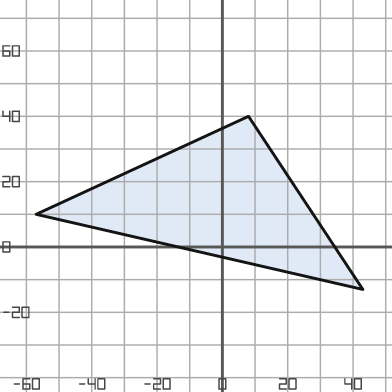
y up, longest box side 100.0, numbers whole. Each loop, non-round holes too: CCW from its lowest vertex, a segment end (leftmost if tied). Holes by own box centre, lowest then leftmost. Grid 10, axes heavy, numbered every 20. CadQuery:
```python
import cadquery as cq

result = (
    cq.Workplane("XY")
    .moveTo(43.0, -13.0)
    .lineTo(8.0, 40.0)
    .lineTo(-57.0, 10.0)
    .close()
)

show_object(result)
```